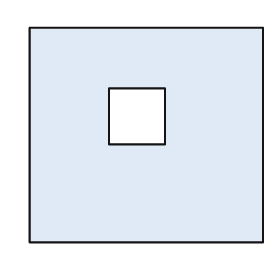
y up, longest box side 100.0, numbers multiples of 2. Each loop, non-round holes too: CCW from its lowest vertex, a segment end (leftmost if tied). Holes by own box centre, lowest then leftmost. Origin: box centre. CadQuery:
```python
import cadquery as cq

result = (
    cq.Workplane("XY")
    .moveTo(-50.0, -46.0)
    .lineTo(50.0, -46.0)
    .lineTo(50.0, 46.0)
    .lineTo(-50.0, 46.0)
    .close()
    .moveTo(-16.0, -4.0)
    .lineTo(8.0, -4.0)
    .lineTo(8.0, 20.0)
    .lineTo(-16.0, 20.0)
    .close()
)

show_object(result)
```